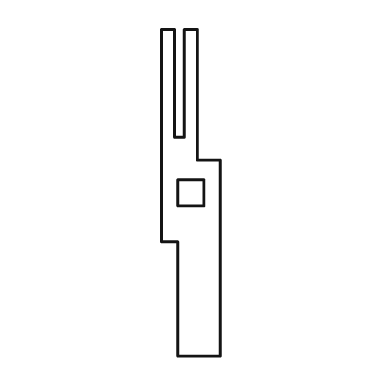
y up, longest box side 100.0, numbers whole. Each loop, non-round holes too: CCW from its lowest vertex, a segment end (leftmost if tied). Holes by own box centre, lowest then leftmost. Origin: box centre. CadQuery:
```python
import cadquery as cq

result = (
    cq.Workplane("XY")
    .moveTo(-4.0, -50.0)
    .lineTo(9.0, -50.0)
    .lineTo(9.0, 10.0)
    .lineTo(2.0, 10.0)
    .lineTo(2.0, 50.0)
    .lineTo(-2.0, 50.0)
    .lineTo(-2.0, 17.0)
    .lineTo(-5.0, 17.0)
    .lineTo(-5.0, 50.0)
    .lineTo(-9.0, 50.0)
    .lineTo(-9.0, -15.0)
    .lineTo(-4.0, -15.0)
    .close()
    .moveTo(-4.0, -4.0)
    .lineTo(4.0, -4.0)
    .lineTo(4.0, 4.0)
    .lineTo(-4.0, 4.0)
    .close()
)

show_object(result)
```